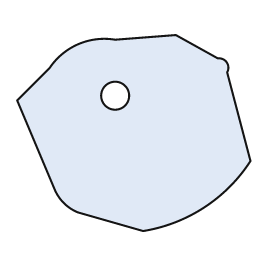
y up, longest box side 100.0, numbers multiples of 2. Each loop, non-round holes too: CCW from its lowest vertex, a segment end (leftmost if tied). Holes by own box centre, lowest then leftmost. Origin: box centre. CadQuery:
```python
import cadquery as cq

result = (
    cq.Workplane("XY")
    .moveTo(4.0, -42.0)
    .threePointArc((30.0, -32.0), (50.0, -12.0))
    .lineTo(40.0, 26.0)
    .threePointArc((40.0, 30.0), (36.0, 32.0))
    .lineTo(18.0, 42.0)
    .lineTo(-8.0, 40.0)
    .threePointArc((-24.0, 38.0), (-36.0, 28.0))
    .lineTo(-50.0, 14.0)
    .lineTo(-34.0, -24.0)
    .threePointArc((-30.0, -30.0), (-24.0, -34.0))
    .close()
    .moveTo(-8.0, 16.0)
    .circle(6.0)
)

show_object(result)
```